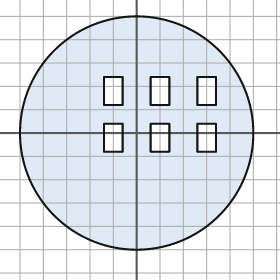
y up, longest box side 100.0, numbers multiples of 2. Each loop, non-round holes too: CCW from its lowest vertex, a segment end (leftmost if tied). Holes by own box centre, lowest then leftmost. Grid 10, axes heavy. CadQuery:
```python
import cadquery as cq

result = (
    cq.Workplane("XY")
    .moveTo(0.0, 0.0)
    .circle(50.0)
    .moveTo(-14.0, -8.0)
    .lineTo(-6.0, -8.0)
    .lineTo(-6.0, 4.0)
    .lineTo(-14.0, 4.0)
    .close()
    .moveTo(6.0, -8.0)
    .lineTo(14.0, -8.0)
    .lineTo(14.0, 4.0)
    .lineTo(6.0, 4.0)
    .close()
    .moveTo(26.0, -8.0)
    .lineTo(34.0, -8.0)
    .lineTo(34.0, 4.0)
    .lineTo(26.0, 4.0)
    .close()
    .moveTo(-14.0, 12.0)
    .lineTo(-6.0, 12.0)
    .lineTo(-6.0, 24.0)
    .lineTo(-14.0, 24.0)
    .close()
    .moveTo(6.0, 12.0)
    .lineTo(14.0, 12.0)
    .lineTo(14.0, 24.0)
    .lineTo(6.0, 24.0)
    .close()
    .moveTo(26.0, 12.0)
    .lineTo(34.0, 12.0)
    .lineTo(34.0, 24.0)
    .lineTo(26.0, 24.0)
    .close()
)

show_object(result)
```